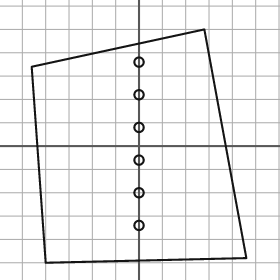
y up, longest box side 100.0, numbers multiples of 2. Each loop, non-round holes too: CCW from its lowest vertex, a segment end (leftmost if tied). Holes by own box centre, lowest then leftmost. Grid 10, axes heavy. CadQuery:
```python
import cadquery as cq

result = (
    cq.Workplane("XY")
    .moveTo(-40.0, -50.0)
    .lineTo(46.0, -48.0)
    .lineTo(28.0, 50.0)
    .lineTo(-46.0, 34.0)
    .close()
    .moveTo(0.0, -34.0)
    .circle(2.0)
    .moveTo(0.0, -20.0)
    .circle(2.0)
    .moveTo(0.0, -6.0)
    .circle(2.0)
    .moveTo(0.0, 8.0)
    .circle(2.0)
    .moveTo(0.0, 22.0)
    .circle(2.0)
    .moveTo(0.0, 36.0)
    .circle(2.0)
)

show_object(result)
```